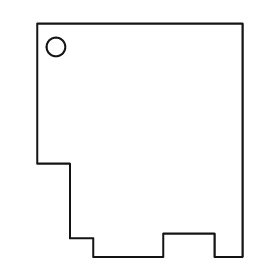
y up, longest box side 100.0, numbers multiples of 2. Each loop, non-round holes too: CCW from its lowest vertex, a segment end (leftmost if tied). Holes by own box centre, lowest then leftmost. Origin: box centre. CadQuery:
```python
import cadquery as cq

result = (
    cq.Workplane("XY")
    .moveTo(-20.0, -50.0)
    .lineTo(10.0, -50.0)
    .lineTo(10.0, -40.0)
    .lineTo(32.0, -40.0)
    .lineTo(32.0, -50.0)
    .lineTo(44.0, -50.0)
    .lineTo(44.0, 50.0)
    .lineTo(-44.0, 50.0)
    .lineTo(-44.0, -10.0)
    .lineTo(-30.0, -10.0)
    .lineTo(-30.0, -42.0)
    .lineTo(-20.0, -42.0)
    .close()
    .moveTo(-36.0, 40.0)
    .circle(4.0)
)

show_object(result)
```